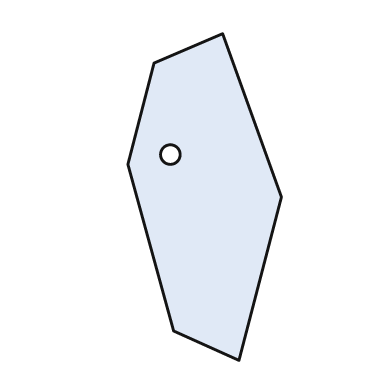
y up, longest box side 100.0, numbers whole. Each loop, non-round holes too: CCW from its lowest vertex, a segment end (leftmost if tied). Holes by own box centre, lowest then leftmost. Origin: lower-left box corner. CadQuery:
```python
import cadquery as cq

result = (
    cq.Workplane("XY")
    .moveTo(34.0, 0.0)
    .lineTo(47.0, 50.0)
    .lineTo(29.0, 100.0)
    .lineTo(8.0, 91.0)
    .lineTo(0.0, 60.0)
    .lineTo(14.0, 9.0)
    .close()
    .moveTo(13.0, 63.0)
    .circle(3.0)
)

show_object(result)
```